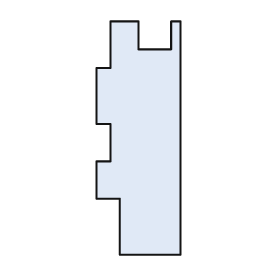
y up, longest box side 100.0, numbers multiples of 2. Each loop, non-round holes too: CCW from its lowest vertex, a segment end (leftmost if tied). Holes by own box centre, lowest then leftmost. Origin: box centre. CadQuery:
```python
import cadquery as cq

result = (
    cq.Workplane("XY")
    .moveTo(-8.0, -50.0)
    .lineTo(18.0, -50.0)
    .lineTo(18.0, 50.0)
    .lineTo(14.0, 50.0)
    .lineTo(14.0, 38.0)
    .lineTo(0.0, 38.0)
    .lineTo(0.0, 50.0)
    .lineTo(-12.0, 50.0)
    .lineTo(-12.0, 30.0)
    .lineTo(-18.0, 30.0)
    .lineTo(-18.0, 6.0)
    .lineTo(-12.0, 6.0)
    .lineTo(-12.0, -10.0)
    .lineTo(-18.0, -10.0)
    .lineTo(-18.0, -26.0)
    .lineTo(-8.0, -26.0)
    .close()
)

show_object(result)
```